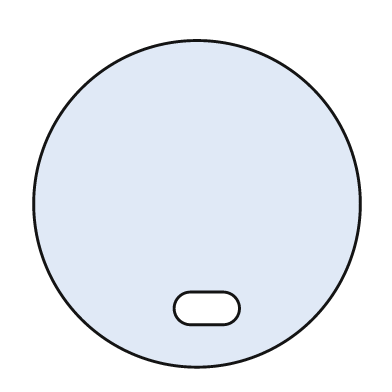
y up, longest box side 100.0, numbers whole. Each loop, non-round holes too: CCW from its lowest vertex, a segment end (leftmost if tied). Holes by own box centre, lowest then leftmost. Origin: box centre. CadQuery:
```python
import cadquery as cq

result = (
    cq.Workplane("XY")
    .moveTo(0.0, 0.0)
    .circle(50.0)
    .moveTo(-2.0, -37.0)
    .lineTo(8.0, -37.0)
    .threePointArc((13.0, -32.0), (8.0, -27.0))
    .lineTo(-2.0, -27.0)
    .threePointArc((-7.0, -32.0), (-2.0, -37.0))
    .close()
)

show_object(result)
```